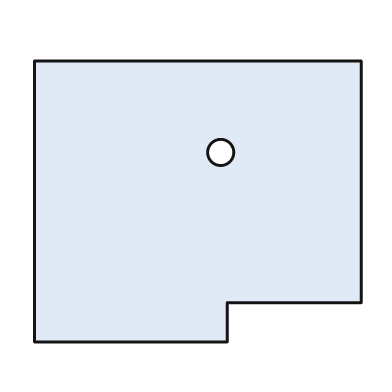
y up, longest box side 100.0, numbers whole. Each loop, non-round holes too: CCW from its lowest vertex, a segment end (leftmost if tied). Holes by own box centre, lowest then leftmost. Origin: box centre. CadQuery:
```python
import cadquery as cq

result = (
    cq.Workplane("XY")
    .moveTo(-50.0, -43.0)
    .lineTo(9.0, -43.0)
    .lineTo(9.0, -31.0)
    .lineTo(50.0, -31.0)
    .lineTo(50.0, 43.0)
    .lineTo(-50.0, 43.0)
    .close()
    .moveTo(7.0, 15.0)
    .circle(4.0)
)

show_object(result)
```